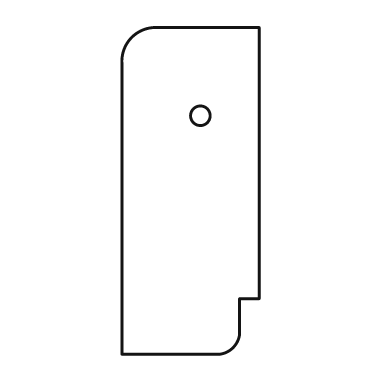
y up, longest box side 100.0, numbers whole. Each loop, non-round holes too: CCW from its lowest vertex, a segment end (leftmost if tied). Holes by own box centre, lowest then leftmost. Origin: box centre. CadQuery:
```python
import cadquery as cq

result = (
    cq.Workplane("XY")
    .moveTo(-21.0, -50.0)
    .lineTo(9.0, -50.0)
    .threePointArc((13.0, -48.0), (15.0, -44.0))
    .lineTo(15.0, -33.0)
    .lineTo(21.0, -33.0)
    .lineTo(21.0, 50.0)
    .lineTo(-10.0, 50.0)
    .threePointArc((-18.0, 47.0), (-21.0, 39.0))
    .close()
    .moveTo(3.0, 23.0)
    .circle(3.0)
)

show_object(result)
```